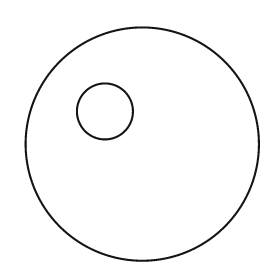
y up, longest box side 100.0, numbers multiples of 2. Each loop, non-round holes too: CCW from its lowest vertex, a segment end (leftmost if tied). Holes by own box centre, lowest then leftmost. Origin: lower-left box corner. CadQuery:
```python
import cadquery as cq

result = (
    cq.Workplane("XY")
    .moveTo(50.0, 50.0)
    .circle(50.0)
    .moveTo(34.0, 64.0)
    .circle(12.0)
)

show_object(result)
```